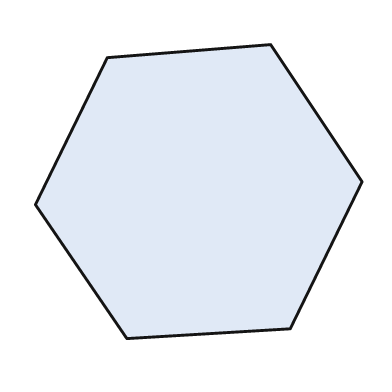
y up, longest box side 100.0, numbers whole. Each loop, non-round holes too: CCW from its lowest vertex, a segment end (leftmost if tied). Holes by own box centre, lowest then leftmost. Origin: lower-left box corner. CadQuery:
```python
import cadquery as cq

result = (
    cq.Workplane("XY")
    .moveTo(28.0, 0.0)
    .lineTo(78.0, 3.0)
    .lineTo(100.0, 48.0)
    .lineTo(72.0, 90.0)
    .lineTo(22.0, 86.0)
    .lineTo(0.0, 41.0)
    .close()
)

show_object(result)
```